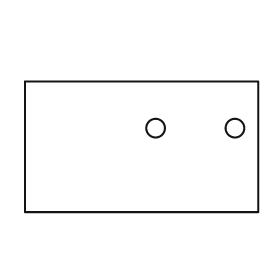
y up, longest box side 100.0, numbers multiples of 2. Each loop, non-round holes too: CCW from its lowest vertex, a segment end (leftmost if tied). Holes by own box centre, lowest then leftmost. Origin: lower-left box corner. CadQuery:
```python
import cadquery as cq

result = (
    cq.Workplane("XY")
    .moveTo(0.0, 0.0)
    .lineTo(100.0, 0.0)
    .lineTo(100.0, 56.0)
    .lineTo(0.0, 56.0)
    .close()
    .moveTo(56.0, 36.0)
    .circle(4.0)
    .moveTo(90.0, 36.0)
    .circle(4.0)
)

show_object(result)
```